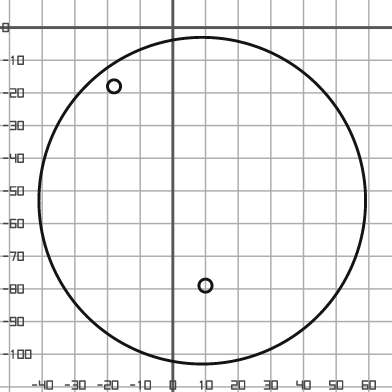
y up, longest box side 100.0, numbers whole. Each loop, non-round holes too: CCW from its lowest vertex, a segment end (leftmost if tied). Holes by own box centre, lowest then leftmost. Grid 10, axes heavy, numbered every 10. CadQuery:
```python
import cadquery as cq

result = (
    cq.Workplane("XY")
    .moveTo(9.0, -53.0)
    .circle(50.0)
    .moveTo(10.0, -79.0)
    .circle(2.0)
    .moveTo(-18.0, -18.0)
    .circle(2.0)
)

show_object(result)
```